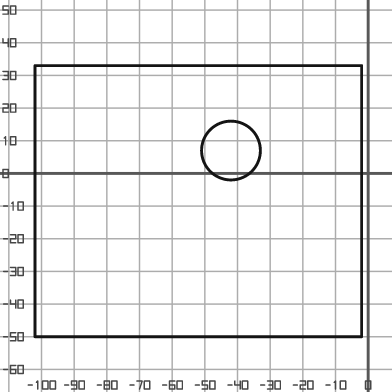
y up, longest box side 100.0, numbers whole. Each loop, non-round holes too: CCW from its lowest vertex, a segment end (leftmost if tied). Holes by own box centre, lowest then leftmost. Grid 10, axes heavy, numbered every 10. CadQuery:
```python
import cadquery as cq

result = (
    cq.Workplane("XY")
    .moveTo(-102.0, -50.0)
    .lineTo(-2.0, -50.0)
    .lineTo(-2.0, 33.0)
    .lineTo(-102.0, 33.0)
    .close()
    .moveTo(-42.0, 7.0)
    .circle(9.0)
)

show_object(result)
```